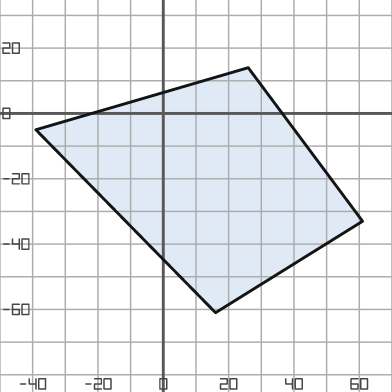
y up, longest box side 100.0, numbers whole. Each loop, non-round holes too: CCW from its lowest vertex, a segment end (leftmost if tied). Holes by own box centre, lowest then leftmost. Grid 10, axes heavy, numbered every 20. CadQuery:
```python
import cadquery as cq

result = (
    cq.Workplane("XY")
    .moveTo(16.0, -61.0)
    .lineTo(61.0, -33.0)
    .lineTo(26.0, 14.0)
    .lineTo(-39.0, -5.0)
    .close()
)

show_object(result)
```